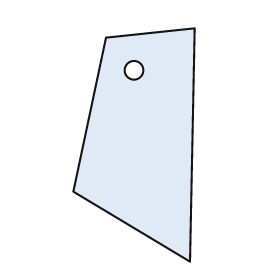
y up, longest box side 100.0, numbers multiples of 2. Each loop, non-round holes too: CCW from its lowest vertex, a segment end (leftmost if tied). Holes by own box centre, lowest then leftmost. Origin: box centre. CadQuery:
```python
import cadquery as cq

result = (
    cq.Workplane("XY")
    .moveTo(24.0, -50.0)
    .lineTo(26.0, 50.0)
    .lineTo(-12.0, 46.0)
    .lineTo(-26.0, -20.0)
    .close()
    .moveTo(0.0, 32.0)
    .circle(4.0)
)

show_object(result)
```